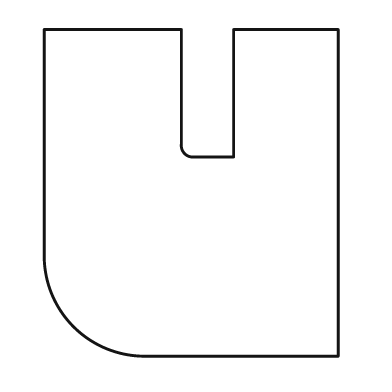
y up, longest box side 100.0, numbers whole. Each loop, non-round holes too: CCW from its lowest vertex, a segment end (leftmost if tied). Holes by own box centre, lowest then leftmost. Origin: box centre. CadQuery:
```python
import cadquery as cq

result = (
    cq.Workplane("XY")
    .moveTo(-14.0, -50.0)
    .lineTo(45.0, -50.0)
    .lineTo(45.0, 50.0)
    .lineTo(13.0, 50.0)
    .lineTo(13.0, 11.0)
    .lineTo(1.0, 11.0)
    .threePointArc((-2.0, 12.0), (-3.0, 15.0))
    .lineTo(-3.0, 50.0)
    .lineTo(-45.0, 50.0)
    .lineTo(-45.0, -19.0)
    .threePointArc((-36.0, -41.0), (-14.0, -50.0))
    .close()
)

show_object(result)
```